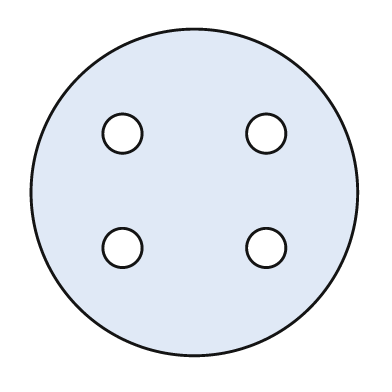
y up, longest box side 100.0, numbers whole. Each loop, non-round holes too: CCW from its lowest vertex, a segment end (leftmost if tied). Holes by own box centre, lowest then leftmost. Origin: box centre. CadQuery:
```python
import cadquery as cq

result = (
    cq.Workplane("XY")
    .moveTo(0.0, 0.0)
    .circle(50.0)
    .moveTo(-22.0, -17.0)
    .circle(6.0)
    .moveTo(22.0, -17.0)
    .circle(6.0)
    .moveTo(-22.0, 18.0)
    .circle(6.0)
    .moveTo(22.0, 18.0)
    .circle(6.0)
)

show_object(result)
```